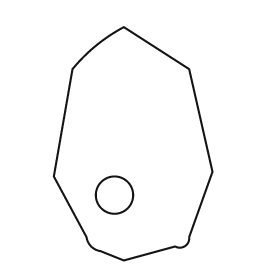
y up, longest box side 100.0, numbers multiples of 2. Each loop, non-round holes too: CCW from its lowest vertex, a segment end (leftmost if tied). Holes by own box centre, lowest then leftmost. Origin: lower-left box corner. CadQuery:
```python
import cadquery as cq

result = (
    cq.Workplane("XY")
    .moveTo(30.0, 0.0)
    .lineTo(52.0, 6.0)
    .threePointArc((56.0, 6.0), (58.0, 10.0))
    .lineTo(68.0, 38.0)
    .lineTo(58.0, 82.0)
    .lineTo(30.0, 100.0)
    .threePointArc((18.0, 92.0), (8.0, 82.0))
    .lineTo(0.0, 36.0)
    .lineTo(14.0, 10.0)
    .threePointArc((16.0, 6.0), (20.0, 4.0))
    .close()
    .moveTo(26.0, 28.0)
    .circle(8.0)
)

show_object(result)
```